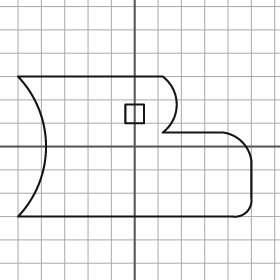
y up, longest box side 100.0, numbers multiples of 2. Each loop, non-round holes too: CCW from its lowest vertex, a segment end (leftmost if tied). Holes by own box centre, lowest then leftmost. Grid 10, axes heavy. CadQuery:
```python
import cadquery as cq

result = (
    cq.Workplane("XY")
    .moveTo(-50.0, -30.0)
    .lineTo(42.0, -30.0)
    .threePointArc((48.0, -28.0), (50.0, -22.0))
    .lineTo(50.0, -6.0)
    .threePointArc((46.0, 2.0), (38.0, 6.0))
    .lineTo(12.0, 6.0)
    .threePointArc((18.0, 18.0), (12.0, 30.0))
    .lineTo(-50.0, 30.0)
    .threePointArc((-38.0, 0.0), (-50.0, -30.0))
    .close()
    .moveTo(-4.0, 10.0)
    .lineTo(4.0, 10.0)
    .lineTo(4.0, 18.0)
    .lineTo(-4.0, 18.0)
    .close()
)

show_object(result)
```